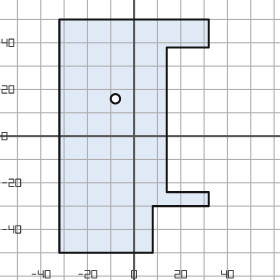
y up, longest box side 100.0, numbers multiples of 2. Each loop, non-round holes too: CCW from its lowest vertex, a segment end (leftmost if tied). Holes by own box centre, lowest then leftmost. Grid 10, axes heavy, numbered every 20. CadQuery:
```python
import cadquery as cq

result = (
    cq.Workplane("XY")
    .moveTo(-32.0, -50.0)
    .lineTo(8.0, -50.0)
    .lineTo(8.0, -30.0)
    .lineTo(32.0, -30.0)
    .lineTo(32.0, -24.0)
    .lineTo(14.0, -24.0)
    .lineTo(14.0, 38.0)
    .lineTo(32.0, 38.0)
    .lineTo(32.0, 50.0)
    .lineTo(-32.0, 50.0)
    .close()
    .moveTo(-8.0, 16.0)
    .circle(2.0)
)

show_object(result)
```